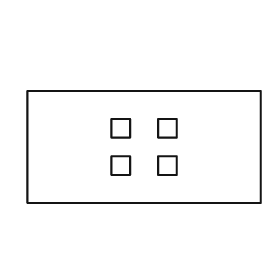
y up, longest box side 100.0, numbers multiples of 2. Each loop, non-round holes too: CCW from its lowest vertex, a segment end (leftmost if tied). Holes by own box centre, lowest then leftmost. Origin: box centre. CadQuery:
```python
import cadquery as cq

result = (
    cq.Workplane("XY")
    .moveTo(-50.0, -24.0)
    .lineTo(50.0, -24.0)
    .lineTo(50.0, 24.0)
    .lineTo(-50.0, 24.0)
    .close()
    .moveTo(-14.0, -12.0)
    .lineTo(-6.0, -12.0)
    .lineTo(-6.0, -4.0)
    .lineTo(-14.0, -4.0)
    .close()
    .moveTo(6.0, -12.0)
    .lineTo(14.0, -12.0)
    .lineTo(14.0, -4.0)
    .lineTo(6.0, -4.0)
    .close()
    .moveTo(-14.0, 4.0)
    .lineTo(-6.0, 4.0)
    .lineTo(-6.0, 12.0)
    .lineTo(-14.0, 12.0)
    .close()
    .moveTo(6.0, 4.0)
    .lineTo(14.0, 4.0)
    .lineTo(14.0, 12.0)
    .lineTo(6.0, 12.0)
    .close()
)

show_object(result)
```